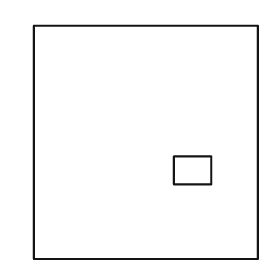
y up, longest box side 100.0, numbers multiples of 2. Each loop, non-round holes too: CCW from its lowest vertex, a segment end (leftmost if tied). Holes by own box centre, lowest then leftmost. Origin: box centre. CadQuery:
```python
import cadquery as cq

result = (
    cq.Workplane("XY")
    .moveTo(-48.0, -50.0)
    .lineTo(48.0, -50.0)
    .lineTo(48.0, 50.0)
    .lineTo(-48.0, 50.0)
    .close()
    .moveTo(12.0, -18.0)
    .lineTo(28.0, -18.0)
    .lineTo(28.0, -6.0)
    .lineTo(12.0, -6.0)
    .close()
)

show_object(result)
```